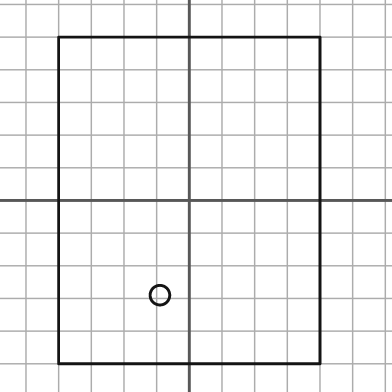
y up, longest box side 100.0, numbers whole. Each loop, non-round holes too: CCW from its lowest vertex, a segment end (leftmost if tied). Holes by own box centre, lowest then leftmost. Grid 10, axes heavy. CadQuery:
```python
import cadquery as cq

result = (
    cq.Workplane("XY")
    .moveTo(-40.0, -50.0)
    .lineTo(40.0, -50.0)
    .lineTo(40.0, 50.0)
    .lineTo(-40.0, 50.0)
    .close()
    .moveTo(-9.0, -29.0)
    .circle(3.0)
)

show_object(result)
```